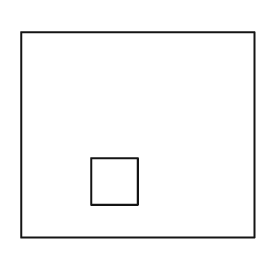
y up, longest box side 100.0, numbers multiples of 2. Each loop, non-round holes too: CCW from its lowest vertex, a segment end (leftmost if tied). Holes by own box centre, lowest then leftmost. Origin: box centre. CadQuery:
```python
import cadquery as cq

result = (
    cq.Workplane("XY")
    .moveTo(-50.0, -44.0)
    .lineTo(50.0, -44.0)
    .lineTo(50.0, 44.0)
    .lineTo(-50.0, 44.0)
    .close()
    .moveTo(-20.0, -30.0)
    .lineTo(0.0, -30.0)
    .lineTo(0.0, -10.0)
    .lineTo(-20.0, -10.0)
    .close()
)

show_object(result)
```